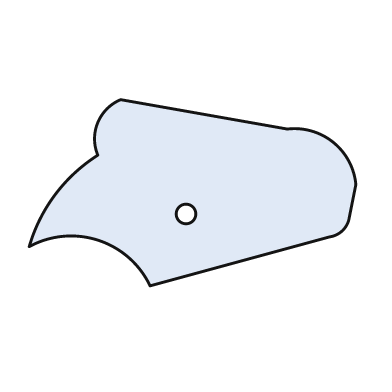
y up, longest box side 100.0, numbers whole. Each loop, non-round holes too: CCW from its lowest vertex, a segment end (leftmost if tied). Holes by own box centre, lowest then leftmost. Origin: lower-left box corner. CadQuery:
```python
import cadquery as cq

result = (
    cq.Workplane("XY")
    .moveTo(37.0, 0.0)
    .lineTo(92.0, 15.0)
    .threePointArc((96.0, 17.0), (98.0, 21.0))
    .lineTo(100.0, 31.0)
    .threePointArc((93.0, 44.0), (79.0, 48.0))
    .lineTo(28.0, 57.0)
    .threePointArc((21.0, 50.0), (21.0, 40.0))
    .threePointArc((8.0, 28.0), (0.0, 12.0))
    .threePointArc((21.0, 14.0), (37.0, 0.0))
    .close()
    .moveTo(48.0, 22.0)
    .circle(3.0)
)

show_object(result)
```